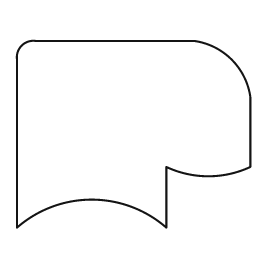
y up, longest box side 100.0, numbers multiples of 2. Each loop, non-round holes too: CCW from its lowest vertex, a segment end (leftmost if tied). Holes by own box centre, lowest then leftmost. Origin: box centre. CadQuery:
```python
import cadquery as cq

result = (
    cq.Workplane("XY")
    .moveTo(-50.0, -40.0)
    .threePointArc((-18.0, -28.0), (14.0, -40.0))
    .lineTo(14.0, -14.0)
    .threePointArc((32.0, -18.0), (50.0, -14.0))
    .lineTo(50.0, 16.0)
    .threePointArc((42.0, 32.0), (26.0, 40.0))
    .lineTo(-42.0, 40.0)
    .threePointArc((-48.0, 38.0), (-50.0, 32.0))
    .close()
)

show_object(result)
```